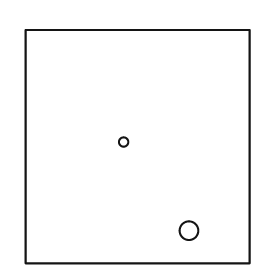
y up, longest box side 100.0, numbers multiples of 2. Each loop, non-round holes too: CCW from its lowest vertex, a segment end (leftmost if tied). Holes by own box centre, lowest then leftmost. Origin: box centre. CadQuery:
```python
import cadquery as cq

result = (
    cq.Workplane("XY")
    .moveTo(-48.0, -50.0)
    .lineTo(48.0, -50.0)
    .lineTo(48.0, 50.0)
    .lineTo(-48.0, 50.0)
    .close()
    .moveTo(22.0, -36.0)
    .circle(4.0)
    .moveTo(-6.0, 2.0)
    .circle(2.0)
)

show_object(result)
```